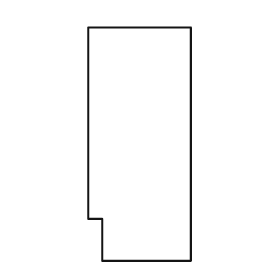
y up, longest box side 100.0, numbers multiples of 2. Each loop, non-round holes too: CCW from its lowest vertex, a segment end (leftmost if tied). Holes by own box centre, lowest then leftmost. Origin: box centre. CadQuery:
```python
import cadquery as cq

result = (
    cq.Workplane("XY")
    .moveTo(-16.0, -50.0)
    .lineTo(22.0, -50.0)
    .lineTo(22.0, 50.0)
    .lineTo(-22.0, 50.0)
    .lineTo(-22.0, -32.0)
    .lineTo(-16.0, -32.0)
    .close()
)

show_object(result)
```